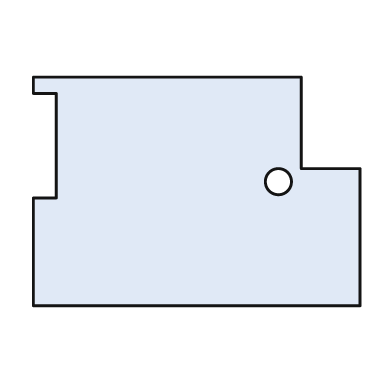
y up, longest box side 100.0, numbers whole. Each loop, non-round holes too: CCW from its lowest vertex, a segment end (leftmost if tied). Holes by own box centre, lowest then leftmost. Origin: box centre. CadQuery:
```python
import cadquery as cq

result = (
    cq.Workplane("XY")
    .moveTo(-50.0, -35.0)
    .lineTo(50.0, -35.0)
    .lineTo(50.0, 7.0)
    .lineTo(32.0, 7.0)
    .lineTo(32.0, 35.0)
    .lineTo(-50.0, 35.0)
    .lineTo(-50.0, 30.0)
    .lineTo(-43.0, 30.0)
    .lineTo(-43.0, -2.0)
    .lineTo(-50.0, -2.0)
    .close()
    .moveTo(25.0, 3.0)
    .circle(4.0)
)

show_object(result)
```